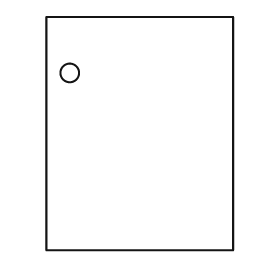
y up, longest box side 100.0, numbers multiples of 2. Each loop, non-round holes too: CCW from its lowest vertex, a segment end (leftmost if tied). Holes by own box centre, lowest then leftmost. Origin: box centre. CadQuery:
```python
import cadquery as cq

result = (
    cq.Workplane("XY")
    .moveTo(-40.0, -50.0)
    .lineTo(40.0, -50.0)
    .lineTo(40.0, 50.0)
    .lineTo(-40.0, 50.0)
    .close()
    .moveTo(-30.0, 26.0)
    .circle(4.0)
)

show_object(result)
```